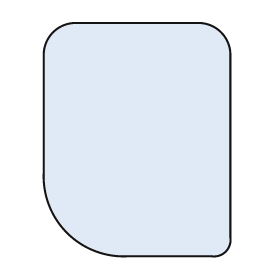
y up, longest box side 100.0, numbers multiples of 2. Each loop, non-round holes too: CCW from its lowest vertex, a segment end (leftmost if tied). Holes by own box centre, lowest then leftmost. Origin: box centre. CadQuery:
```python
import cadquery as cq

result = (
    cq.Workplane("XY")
    .moveTo(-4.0, -50.0)
    .lineTo(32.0, -50.0)
    .threePointArc((38.0, -48.0), (40.0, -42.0))
    .lineTo(40.0, 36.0)
    .threePointArc((36.0, 46.0), (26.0, 50.0))
    .lineTo(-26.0, 50.0)
    .threePointArc((-36.0, 46.0), (-40.0, 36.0))
    .lineTo(-40.0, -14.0)
    .threePointArc((-30.0, -40.0), (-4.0, -50.0))
    .close()
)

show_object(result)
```